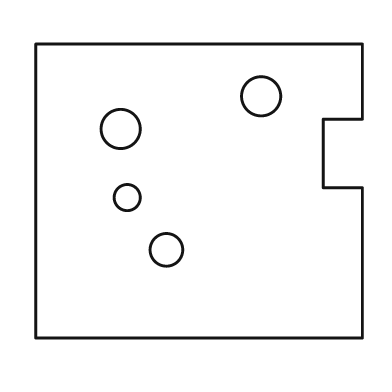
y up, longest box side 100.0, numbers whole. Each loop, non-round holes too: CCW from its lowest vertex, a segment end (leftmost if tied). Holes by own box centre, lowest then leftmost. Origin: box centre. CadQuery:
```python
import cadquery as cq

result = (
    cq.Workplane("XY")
    .moveTo(-50.0, -45.0)
    .lineTo(50.0, -45.0)
    .lineTo(50.0, 1.0)
    .lineTo(38.0, 1.0)
    .lineTo(38.0, 22.0)
    .lineTo(50.0, 22.0)
    .lineTo(50.0, 45.0)
    .lineTo(-50.0, 45.0)
    .close()
    .moveTo(-10.0, -18.0)
    .circle(5.0)
    .moveTo(-22.0, -2.0)
    .circle(4.0)
    .moveTo(-24.0, 19.0)
    .circle(6.0)
    .moveTo(19.0, 29.0)
    .circle(6.0)
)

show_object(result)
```